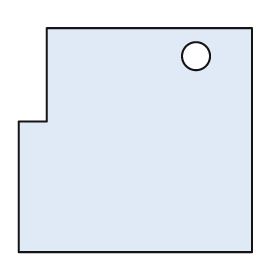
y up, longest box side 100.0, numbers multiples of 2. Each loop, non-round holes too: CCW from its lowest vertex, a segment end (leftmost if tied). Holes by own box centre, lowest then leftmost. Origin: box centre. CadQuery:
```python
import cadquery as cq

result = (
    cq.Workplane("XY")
    .moveTo(-50.0, -48.0)
    .lineTo(50.0, -48.0)
    .lineTo(50.0, 48.0)
    .lineTo(-38.0, 48.0)
    .lineTo(-38.0, 8.0)
    .lineTo(-50.0, 8.0)
    .close()
    .moveTo(26.0, 36.0)
    .circle(6.0)
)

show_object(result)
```